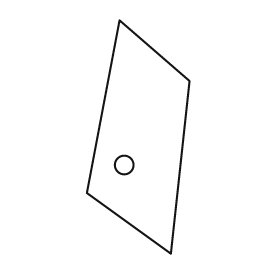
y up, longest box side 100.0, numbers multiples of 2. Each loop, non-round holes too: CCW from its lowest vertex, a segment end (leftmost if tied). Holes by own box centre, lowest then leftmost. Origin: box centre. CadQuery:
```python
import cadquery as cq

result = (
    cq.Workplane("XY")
    .moveTo(14.0, -50.0)
    .lineTo(22.0, 24.0)
    .lineTo(-8.0, 50.0)
    .lineTo(-22.0, -24.0)
    .close()
    .moveTo(-6.0, -12.0)
    .circle(4.0)
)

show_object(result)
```